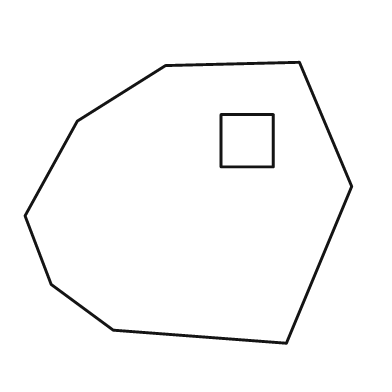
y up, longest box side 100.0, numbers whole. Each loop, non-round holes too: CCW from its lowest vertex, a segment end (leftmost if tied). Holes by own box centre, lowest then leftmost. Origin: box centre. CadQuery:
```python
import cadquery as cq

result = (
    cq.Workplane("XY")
    .moveTo(30.0, -43.0)
    .lineTo(50.0, 5.0)
    .lineTo(34.0, 43.0)
    .lineTo(-7.0, 42.0)
    .lineTo(-34.0, 25.0)
    .lineTo(-50.0, -4.0)
    .lineTo(-42.0, -25.0)
    .lineTo(-23.0, -39.0)
    .close()
    .moveTo(10.0, 11.0)
    .lineTo(26.0, 11.0)
    .lineTo(26.0, 27.0)
    .lineTo(10.0, 27.0)
    .close()
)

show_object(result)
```